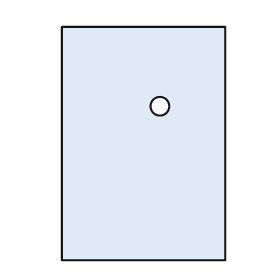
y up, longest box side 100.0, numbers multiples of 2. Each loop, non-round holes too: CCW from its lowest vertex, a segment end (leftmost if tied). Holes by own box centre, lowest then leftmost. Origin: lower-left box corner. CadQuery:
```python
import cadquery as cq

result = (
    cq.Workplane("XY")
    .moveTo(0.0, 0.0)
    .lineTo(70.0, 0.0)
    .lineTo(70.0, 100.0)
    .lineTo(0.0, 100.0)
    .close()
    .moveTo(42.0, 66.0)
    .circle(4.0)
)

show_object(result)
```